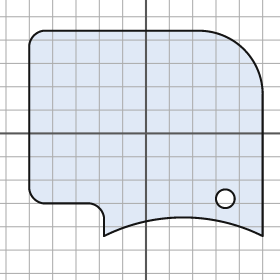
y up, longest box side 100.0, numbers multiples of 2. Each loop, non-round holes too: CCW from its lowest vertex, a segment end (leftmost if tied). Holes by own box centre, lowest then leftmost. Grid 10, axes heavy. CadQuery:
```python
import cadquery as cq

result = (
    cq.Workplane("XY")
    .moveTo(-18.0, -44.0)
    .threePointArc((16.0, -36.0), (50.0, -44.0))
    .lineTo(50.0, 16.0)
    .threePointArc((42.0, 36.0), (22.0, 44.0))
    .lineTo(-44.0, 44.0)
    .threePointArc((-48.0, 42.0), (-50.0, 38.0))
    .lineTo(-50.0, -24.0)
    .threePointArc((-48.0, -28.0), (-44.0, -30.0))
    .lineTo(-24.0, -30.0)
    .threePointArc((-20.0, -32.0), (-18.0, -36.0))
    .close()
    .moveTo(34.0, -28.0)
    .circle(4.0)
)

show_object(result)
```